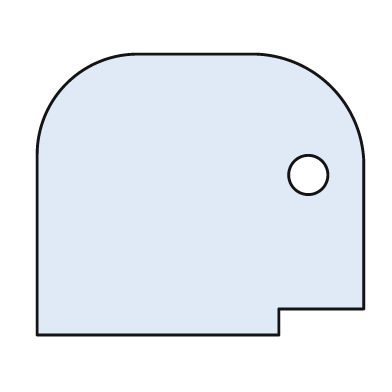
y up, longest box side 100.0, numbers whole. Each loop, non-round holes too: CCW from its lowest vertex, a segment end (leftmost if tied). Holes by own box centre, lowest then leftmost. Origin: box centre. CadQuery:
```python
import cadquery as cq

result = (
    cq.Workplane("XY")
    .moveTo(-50.0, -43.0)
    .lineTo(24.0, -43.0)
    .lineTo(24.0, -35.0)
    .lineTo(50.0, -35.0)
    .lineTo(50.0, 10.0)
    .threePointArc((40.0, 33.0), (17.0, 43.0))
    .lineTo(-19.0, 43.0)
    .threePointArc((-41.0, 34.0), (-50.0, 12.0))
    .close()
    .moveTo(33.0, 6.0)
    .circle(6.0)
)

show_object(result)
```